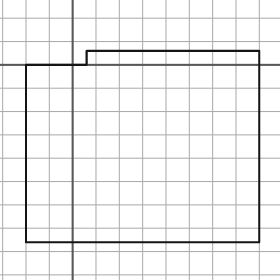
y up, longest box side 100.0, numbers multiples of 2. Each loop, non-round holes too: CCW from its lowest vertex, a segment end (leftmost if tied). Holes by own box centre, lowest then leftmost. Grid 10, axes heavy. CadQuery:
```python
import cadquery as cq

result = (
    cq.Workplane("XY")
    .moveTo(-20.0, -76.0)
    .lineTo(80.0, -76.0)
    .lineTo(80.0, 6.0)
    .lineTo(6.0, 6.0)
    .lineTo(6.0, 0.0)
    .lineTo(-20.0, 0.0)
    .close()
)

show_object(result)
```